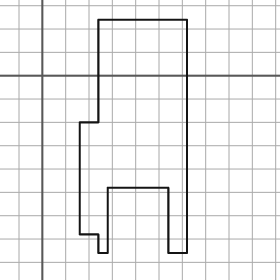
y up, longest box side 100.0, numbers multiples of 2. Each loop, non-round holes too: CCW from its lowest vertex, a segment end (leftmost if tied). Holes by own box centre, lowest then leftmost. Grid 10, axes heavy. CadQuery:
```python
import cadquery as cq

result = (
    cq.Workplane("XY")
    .moveTo(24.0, -76.0)
    .lineTo(28.0, -76.0)
    .lineTo(28.0, -48.0)
    .lineTo(54.0, -48.0)
    .lineTo(54.0, -76.0)
    .lineTo(62.0, -76.0)
    .lineTo(62.0, 24.0)
    .lineTo(24.0, 24.0)
    .lineTo(24.0, -20.0)
    .lineTo(16.0, -20.0)
    .lineTo(16.0, -68.0)
    .lineTo(24.0, -68.0)
    .close()
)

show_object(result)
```